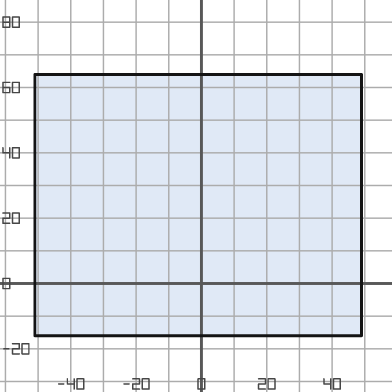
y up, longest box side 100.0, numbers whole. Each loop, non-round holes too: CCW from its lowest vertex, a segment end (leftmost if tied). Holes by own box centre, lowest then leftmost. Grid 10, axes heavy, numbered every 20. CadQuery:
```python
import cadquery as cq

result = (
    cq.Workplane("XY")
    .moveTo(-51.0, -16.0)
    .lineTo(49.0, -16.0)
    .lineTo(49.0, 64.0)
    .lineTo(-51.0, 64.0)
    .close()
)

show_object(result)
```